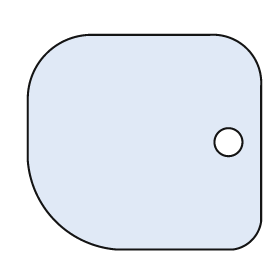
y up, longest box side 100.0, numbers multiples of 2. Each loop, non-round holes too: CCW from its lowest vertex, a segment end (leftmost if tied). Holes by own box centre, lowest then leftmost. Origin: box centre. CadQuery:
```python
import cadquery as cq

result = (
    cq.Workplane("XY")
    .moveTo(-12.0, -46.0)
    .lineTo(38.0, -46.0)
    .threePointArc((46.0, -42.0), (50.0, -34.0))
    .lineTo(50.0, 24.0)
    .threePointArc((44.0, 40.0), (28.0, 46.0))
    .lineTo(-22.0, 46.0)
    .threePointArc((-42.0, 38.0), (-50.0, 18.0))
    .lineTo(-50.0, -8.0)
    .threePointArc((-38.0, -34.0), (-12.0, -46.0))
    .close()
    .moveTo(36.0, 0.0)
    .circle(6.0)
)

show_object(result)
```